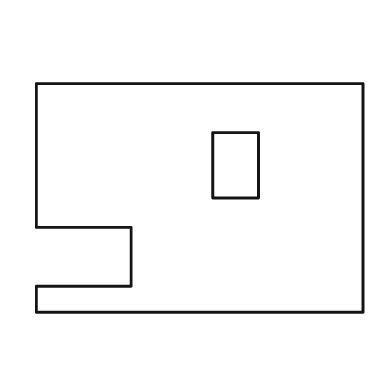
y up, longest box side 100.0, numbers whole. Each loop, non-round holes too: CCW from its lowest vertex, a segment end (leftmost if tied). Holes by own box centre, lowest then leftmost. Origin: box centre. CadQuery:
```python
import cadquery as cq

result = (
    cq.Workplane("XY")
    .moveTo(-50.0, -35.0)
    .lineTo(50.0, -35.0)
    .lineTo(50.0, 35.0)
    .lineTo(-50.0, 35.0)
    .lineTo(-50.0, -9.0)
    .lineTo(-21.0, -9.0)
    .lineTo(-21.0, -27.0)
    .lineTo(-50.0, -27.0)
    .close()
    .moveTo(4.0, 0.0)
    .lineTo(18.0, 0.0)
    .lineTo(18.0, 20.0)
    .lineTo(4.0, 20.0)
    .close()
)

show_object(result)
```